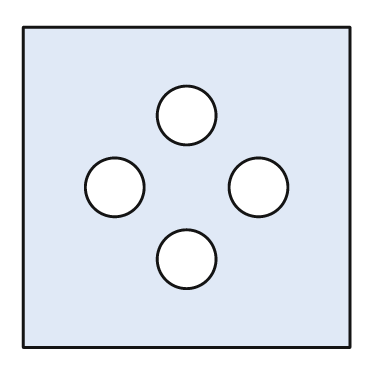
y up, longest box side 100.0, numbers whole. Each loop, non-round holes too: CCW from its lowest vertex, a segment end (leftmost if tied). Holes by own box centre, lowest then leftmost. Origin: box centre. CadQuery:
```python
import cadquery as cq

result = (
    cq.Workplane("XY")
    .moveTo(-50.0, -49.0)
    .lineTo(50.0, -49.0)
    .lineTo(50.0, 49.0)
    .lineTo(-50.0, 49.0)
    .close()
    .moveTo(0.0, -22.0)
    .circle(9.0)
    .moveTo(-22.0, 0.0)
    .circle(9.0)
    .moveTo(22.0, 0.0)
    .circle(9.0)
    .moveTo(0.0, 22.0)
    .circle(9.0)
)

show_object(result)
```